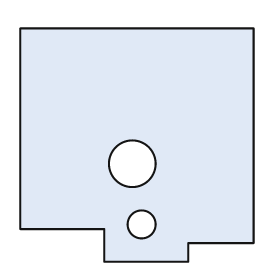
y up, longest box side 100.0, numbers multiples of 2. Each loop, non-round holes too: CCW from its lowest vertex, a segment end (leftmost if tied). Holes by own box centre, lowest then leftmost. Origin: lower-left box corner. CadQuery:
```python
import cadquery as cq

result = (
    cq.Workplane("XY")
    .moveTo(36.0, 0.0)
    .lineTo(72.0, 0.0)
    .lineTo(72.0, 8.0)
    .lineTo(100.0, 8.0)
    .lineTo(100.0, 100.0)
    .lineTo(0.0, 100.0)
    .lineTo(0.0, 14.0)
    .lineTo(36.0, 14.0)
    .close()
    .moveTo(52.0, 16.0)
    .circle(6.0)
    .moveTo(48.0, 42.0)
    .circle(10.0)
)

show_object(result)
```